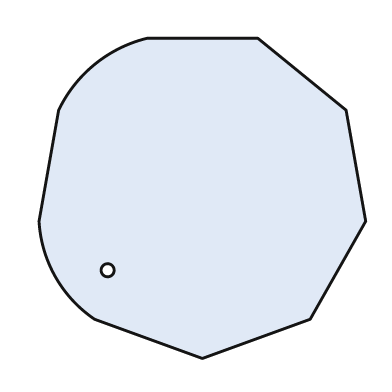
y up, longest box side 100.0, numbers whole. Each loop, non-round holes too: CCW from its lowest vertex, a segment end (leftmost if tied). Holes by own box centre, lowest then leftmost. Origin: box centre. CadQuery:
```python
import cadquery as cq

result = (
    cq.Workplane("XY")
    .moveTo(0.0, -49.0)
    .lineTo(33.0, -37.0)
    .lineTo(50.0, -7.0)
    .lineTo(44.0, 27.0)
    .lineTo(17.0, 49.0)
    .lineTo(-17.0, 49.0)
    .threePointArc((-33.0, 41.0), (-44.0, 27.0))
    .lineTo(-50.0, -7.0)
    .threePointArc((-45.0, -24.0), (-33.0, -37.0))
    .close()
    .moveTo(-29.0, -22.0)
    .circle(2.0)
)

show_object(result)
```